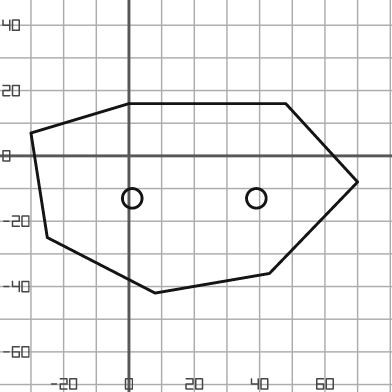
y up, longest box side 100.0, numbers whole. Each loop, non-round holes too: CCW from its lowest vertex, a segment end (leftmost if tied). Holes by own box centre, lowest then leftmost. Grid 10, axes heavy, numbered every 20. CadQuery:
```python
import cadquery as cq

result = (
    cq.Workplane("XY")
    .moveTo(8.0, -42.0)
    .lineTo(43.0, -36.0)
    .lineTo(70.0, -8.0)
    .lineTo(48.0, 16.0)
    .lineTo(0.0, 16.0)
    .lineTo(-30.0, 7.0)
    .lineTo(-25.0, -25.0)
    .close()
    .moveTo(1.0, -13.0)
    .circle(3.0)
    .moveTo(39.0, -13.0)
    .circle(3.0)
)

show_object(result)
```